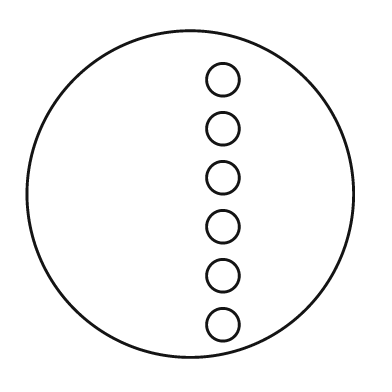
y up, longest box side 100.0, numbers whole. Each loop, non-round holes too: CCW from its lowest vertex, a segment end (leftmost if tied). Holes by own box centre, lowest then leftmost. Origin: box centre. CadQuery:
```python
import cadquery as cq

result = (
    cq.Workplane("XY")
    .moveTo(0.0, 0.0)
    .circle(50.0)
    .moveTo(10.0, -40.0)
    .circle(5.0)
    .moveTo(10.0, -25.0)
    .circle(5.0)
    .moveTo(10.0, -10.0)
    .circle(5.0)
    .moveTo(10.0, 5.0)
    .circle(5.0)
    .moveTo(10.0, 20.0)
    .circle(5.0)
    .moveTo(10.0, 35.0)
    .circle(5.0)
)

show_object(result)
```